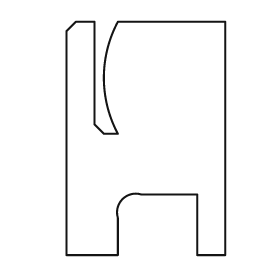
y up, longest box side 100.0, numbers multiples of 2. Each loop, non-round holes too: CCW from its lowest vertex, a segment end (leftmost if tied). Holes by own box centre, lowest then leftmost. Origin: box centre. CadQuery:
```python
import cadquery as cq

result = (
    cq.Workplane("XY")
    .moveTo(-34.0, -50.0)
    .lineTo(-12.0, -50.0)
    .lineTo(-12.0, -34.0)
    .threePointArc((-10.0, -26.0), (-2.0, -24.0))
    .lineTo(22.0, -24.0)
    .lineTo(22.0, -50.0)
    .lineTo(34.0, -50.0)
    .lineTo(34.0, 50.0)
    .lineTo(-12.0, 50.0)
    .threePointArc((-18.0, 26.0), (-12.0, 2.0))
    .lineTo(-18.0, 2.0)
    .lineTo(-22.0, 6.0)
    .lineTo(-22.0, 50.0)
    .lineTo(-30.0, 50.0)
    .lineTo(-34.0, 46.0)
    .close()
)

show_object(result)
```